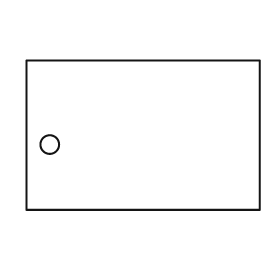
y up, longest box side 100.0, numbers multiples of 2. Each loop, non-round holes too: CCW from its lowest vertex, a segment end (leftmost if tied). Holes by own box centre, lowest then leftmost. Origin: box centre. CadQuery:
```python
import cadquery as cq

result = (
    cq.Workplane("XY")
    .moveTo(-50.0, -32.0)
    .lineTo(50.0, -32.0)
    .lineTo(50.0, 32.0)
    .lineTo(-50.0, 32.0)
    .close()
    .moveTo(-40.0, -4.0)
    .circle(4.0)
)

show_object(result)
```